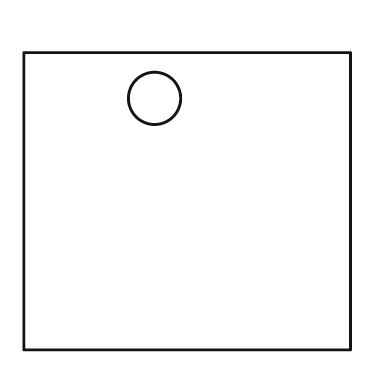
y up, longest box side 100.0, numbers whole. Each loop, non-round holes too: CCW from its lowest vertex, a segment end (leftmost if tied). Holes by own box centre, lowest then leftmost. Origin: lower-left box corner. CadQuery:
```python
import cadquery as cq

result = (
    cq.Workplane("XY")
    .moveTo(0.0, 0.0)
    .lineTo(100.0, 0.0)
    .lineTo(100.0, 91.0)
    .lineTo(0.0, 91.0)
    .close()
    .moveTo(40.0, 77.0)
    .circle(8.0)
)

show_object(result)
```